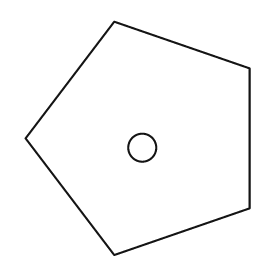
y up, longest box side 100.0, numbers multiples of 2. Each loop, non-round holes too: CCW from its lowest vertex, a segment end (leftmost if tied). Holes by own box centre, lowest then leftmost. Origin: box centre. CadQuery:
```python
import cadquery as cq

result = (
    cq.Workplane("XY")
    .moveTo(-10.0, -50.0)
    .lineTo(48.0, -30.0)
    .lineTo(48.0, 30.0)
    .lineTo(-10.0, 50.0)
    .lineTo(-48.0, 0.0)
    .close()
    .moveTo(2.0, -4.0)
    .circle(6.0)
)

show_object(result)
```